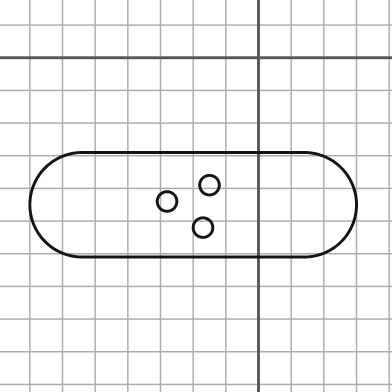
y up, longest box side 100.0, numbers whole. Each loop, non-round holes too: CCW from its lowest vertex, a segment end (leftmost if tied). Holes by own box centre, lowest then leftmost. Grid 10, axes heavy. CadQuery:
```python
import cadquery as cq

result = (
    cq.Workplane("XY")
    .moveTo(-54.0, -61.0)
    .lineTo(14.0, -61.0)
    .threePointArc((30.0, -45.0), (14.0, -29.0))
    .lineTo(-54.0, -29.0)
    .threePointArc((-70.0, -45.0), (-54.0, -61.0))
    .close()
    .moveTo(-17.0, -52.0)
    .circle(3.0)
    .moveTo(-28.0, -44.0)
    .circle(3.0)
    .moveTo(-15.0, -39.0)
    .circle(3.0)
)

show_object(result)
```